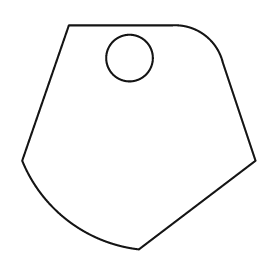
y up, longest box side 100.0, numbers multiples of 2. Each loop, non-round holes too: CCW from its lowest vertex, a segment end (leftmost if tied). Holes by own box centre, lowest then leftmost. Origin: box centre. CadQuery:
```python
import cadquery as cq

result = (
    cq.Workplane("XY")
    .moveTo(0.0, -48.0)
    .lineTo(50.0, -10.0)
    .lineTo(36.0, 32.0)
    .threePointArc((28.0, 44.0), (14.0, 48.0))
    .lineTo(-30.0, 48.0)
    .lineTo(-50.0, -10.0)
    .threePointArc((-30.0, -36.0), (0.0, -48.0))
    .close()
    .moveTo(-4.0, 34.0)
    .circle(10.0)
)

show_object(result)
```